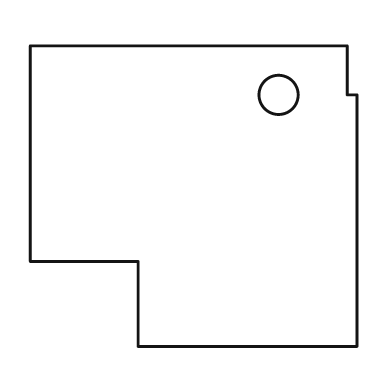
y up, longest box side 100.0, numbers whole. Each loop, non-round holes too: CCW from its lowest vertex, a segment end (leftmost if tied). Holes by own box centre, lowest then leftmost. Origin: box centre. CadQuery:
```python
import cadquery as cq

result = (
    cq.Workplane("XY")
    .moveTo(-17.0, -46.0)
    .lineTo(50.0, -46.0)
    .lineTo(50.0, 31.0)
    .lineTo(47.0, 31.0)
    .lineTo(47.0, 46.0)
    .lineTo(-50.0, 46.0)
    .lineTo(-50.0, -20.0)
    .lineTo(-17.0, -20.0)
    .close()
    .moveTo(26.0, 31.0)
    .circle(6.0)
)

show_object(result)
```